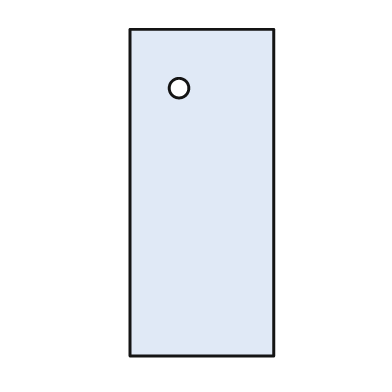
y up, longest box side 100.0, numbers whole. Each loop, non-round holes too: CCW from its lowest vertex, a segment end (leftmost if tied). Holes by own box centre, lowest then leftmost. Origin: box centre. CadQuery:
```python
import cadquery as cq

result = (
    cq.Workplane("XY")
    .moveTo(-22.0, -50.0)
    .lineTo(22.0, -50.0)
    .lineTo(22.0, 50.0)
    .lineTo(-22.0, 50.0)
    .close()
    .moveTo(-7.0, 32.0)
    .circle(3.0)
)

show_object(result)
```